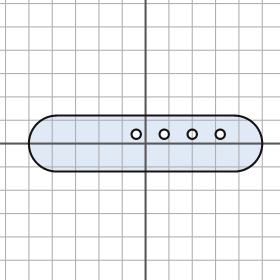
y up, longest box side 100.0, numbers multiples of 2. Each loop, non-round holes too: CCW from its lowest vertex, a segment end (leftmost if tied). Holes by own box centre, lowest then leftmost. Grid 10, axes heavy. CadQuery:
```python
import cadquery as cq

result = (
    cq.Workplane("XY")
    .moveTo(-38.0, -12.0)
    .lineTo(38.0, -12.0)
    .threePointArc((50.0, 0.0), (38.0, 12.0))
    .lineTo(-38.0, 12.0)
    .threePointArc((-50.0, 0.0), (-38.0, -12.0))
    .close()
    .moveTo(-4.0, 4.0)
    .circle(2.0)
    .moveTo(8.0, 4.0)
    .circle(2.0)
    .moveTo(20.0, 4.0)
    .circle(2.0)
    .moveTo(32.0, 4.0)
    .circle(2.0)
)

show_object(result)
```